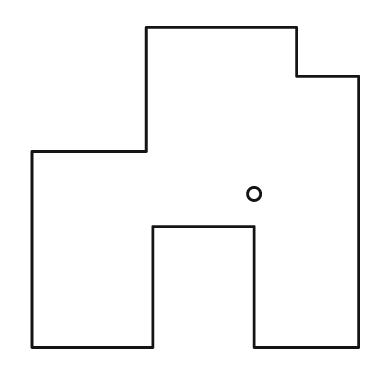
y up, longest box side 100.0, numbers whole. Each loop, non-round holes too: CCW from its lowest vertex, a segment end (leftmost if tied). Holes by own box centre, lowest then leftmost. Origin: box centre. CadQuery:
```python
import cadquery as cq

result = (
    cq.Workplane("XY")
    .moveTo(-50.0, -49.0)
    .lineTo(-13.0, -49.0)
    .lineTo(-13.0, -12.0)
    .lineTo(18.0, -12.0)
    .lineTo(18.0, -49.0)
    .lineTo(50.0, -49.0)
    .lineTo(50.0, 34.0)
    .lineTo(31.0, 34.0)
    .lineTo(31.0, 49.0)
    .lineTo(-15.0, 49.0)
    .lineTo(-15.0, 11.0)
    .lineTo(-50.0, 11.0)
    .close()
    .moveTo(18.0, -2.0)
    .circle(2.0)
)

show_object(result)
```